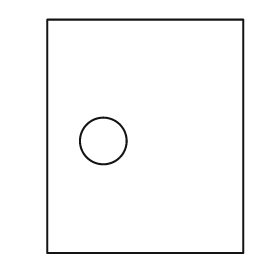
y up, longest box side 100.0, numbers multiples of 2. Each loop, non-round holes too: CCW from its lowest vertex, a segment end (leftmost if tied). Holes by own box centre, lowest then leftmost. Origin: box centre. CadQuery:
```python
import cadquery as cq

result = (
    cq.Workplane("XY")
    .moveTo(-42.0, -50.0)
    .lineTo(42.0, -50.0)
    .lineTo(42.0, 50.0)
    .lineTo(-42.0, 50.0)
    .close()
    .moveTo(-18.0, -2.0)
    .circle(10.0)
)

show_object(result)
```